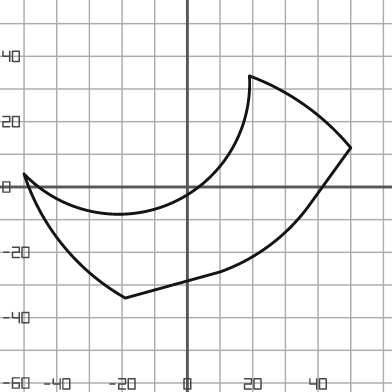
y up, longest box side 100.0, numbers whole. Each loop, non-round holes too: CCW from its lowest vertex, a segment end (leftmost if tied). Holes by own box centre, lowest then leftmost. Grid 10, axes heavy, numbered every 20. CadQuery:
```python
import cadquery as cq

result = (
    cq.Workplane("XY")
    .moveTo(-19.0, -34.0)
    .lineTo(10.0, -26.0)
    .threePointArc((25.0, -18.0), (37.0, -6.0))
    .lineTo(50.0, 12.0)
    .threePointArc((36.0, 25.0), (19.0, 34.0))
    .threePointArc((-5.0, -5.0), (-50.0, 4.0))
    .threePointArc((-38.0, -18.0), (-19.0, -34.0))
    .close()
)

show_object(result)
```